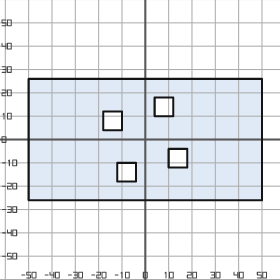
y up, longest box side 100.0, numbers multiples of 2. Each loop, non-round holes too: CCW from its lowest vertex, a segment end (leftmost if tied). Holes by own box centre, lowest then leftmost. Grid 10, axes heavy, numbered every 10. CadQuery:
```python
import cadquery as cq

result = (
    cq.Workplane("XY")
    .moveTo(-50.0, -26.0)
    .lineTo(50.0, -26.0)
    .lineTo(50.0, 26.0)
    .lineTo(-50.0, 26.0)
    .close()
    .moveTo(-12.0, -18.0)
    .lineTo(-4.0, -18.0)
    .lineTo(-4.0, -10.0)
    .lineTo(-12.0, -10.0)
    .close()
    .moveTo(10.0, -12.0)
    .lineTo(18.0, -12.0)
    .lineTo(18.0, -4.0)
    .lineTo(10.0, -4.0)
    .close()
    .moveTo(-18.0, 4.0)
    .lineTo(-10.0, 4.0)
    .lineTo(-10.0, 12.0)
    .lineTo(-18.0, 12.0)
    .close()
    .moveTo(4.0, 10.0)
    .lineTo(12.0, 10.0)
    .lineTo(12.0, 18.0)
    .lineTo(4.0, 18.0)
    .close()
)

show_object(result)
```